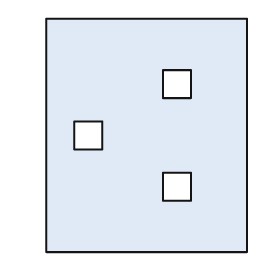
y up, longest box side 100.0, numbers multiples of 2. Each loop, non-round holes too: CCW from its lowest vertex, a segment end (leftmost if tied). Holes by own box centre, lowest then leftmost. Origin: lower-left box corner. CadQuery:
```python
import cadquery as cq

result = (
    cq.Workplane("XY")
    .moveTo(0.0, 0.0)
    .lineTo(86.0, 0.0)
    .lineTo(86.0, 100.0)
    .lineTo(0.0, 100.0)
    .close()
    .moveTo(50.0, 22.0)
    .lineTo(62.0, 22.0)
    .lineTo(62.0, 34.0)
    .lineTo(50.0, 34.0)
    .close()
    .moveTo(12.0, 44.0)
    .lineTo(24.0, 44.0)
    .lineTo(24.0, 56.0)
    .lineTo(12.0, 56.0)
    .close()
    .moveTo(50.0, 66.0)
    .lineTo(62.0, 66.0)
    .lineTo(62.0, 78.0)
    .lineTo(50.0, 78.0)
    .close()
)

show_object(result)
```